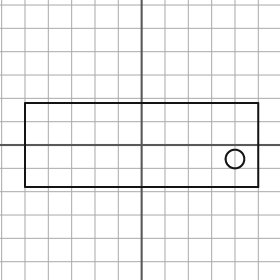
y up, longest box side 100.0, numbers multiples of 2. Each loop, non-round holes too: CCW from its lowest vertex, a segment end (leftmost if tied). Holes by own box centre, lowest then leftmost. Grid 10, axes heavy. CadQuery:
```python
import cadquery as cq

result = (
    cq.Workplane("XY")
    .moveTo(-50.0, -18.0)
    .lineTo(50.0, -18.0)
    .lineTo(50.0, 18.0)
    .lineTo(-50.0, 18.0)
    .close()
    .moveTo(40.0, -6.0)
    .circle(4.0)
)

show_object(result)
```